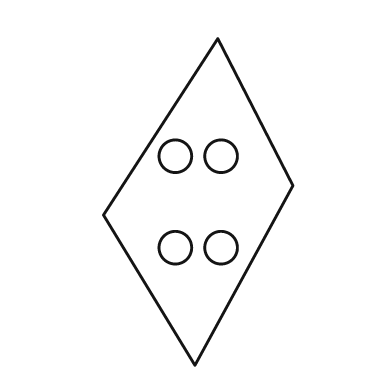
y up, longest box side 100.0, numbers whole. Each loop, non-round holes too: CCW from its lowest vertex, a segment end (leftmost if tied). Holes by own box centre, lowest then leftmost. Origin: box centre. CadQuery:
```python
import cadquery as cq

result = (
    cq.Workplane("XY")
    .moveTo(-1.0, -50.0)
    .lineTo(29.0, 5.0)
    .lineTo(6.0, 50.0)
    .lineTo(-29.0, -4.0)
    .close()
    .moveTo(-7.0, -14.0)
    .circle(5.0)
    .moveTo(7.0, -14.0)
    .circle(5.0)
    .moveTo(-7.0, 14.0)
    .circle(5.0)
    .moveTo(7.0, 14.0)
    .circle(5.0)
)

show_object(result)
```